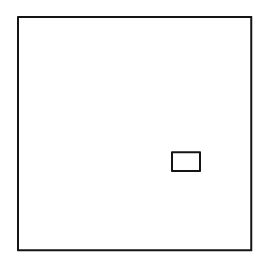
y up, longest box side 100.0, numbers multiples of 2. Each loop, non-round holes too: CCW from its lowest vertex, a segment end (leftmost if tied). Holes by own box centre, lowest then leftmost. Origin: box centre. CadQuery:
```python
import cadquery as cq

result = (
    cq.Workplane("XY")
    .moveTo(-50.0, -50.0)
    .lineTo(50.0, -50.0)
    .lineTo(50.0, 50.0)
    .lineTo(-50.0, 50.0)
    .close()
    .moveTo(16.0, -16.0)
    .lineTo(28.0, -16.0)
    .lineTo(28.0, -8.0)
    .lineTo(16.0, -8.0)
    .close()
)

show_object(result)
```